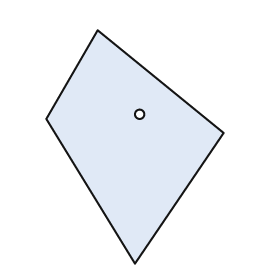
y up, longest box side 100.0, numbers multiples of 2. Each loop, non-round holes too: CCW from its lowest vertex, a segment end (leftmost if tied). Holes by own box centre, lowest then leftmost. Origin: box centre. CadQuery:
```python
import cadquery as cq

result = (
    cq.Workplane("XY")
    .moveTo(0.0, -50.0)
    .lineTo(38.0, 6.0)
    .lineTo(-16.0, 50.0)
    .lineTo(-38.0, 12.0)
    .close()
    .moveTo(2.0, 14.0)
    .circle(2.0)
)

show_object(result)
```